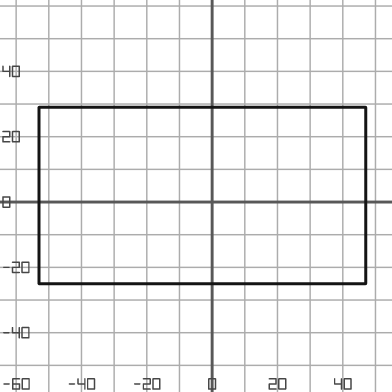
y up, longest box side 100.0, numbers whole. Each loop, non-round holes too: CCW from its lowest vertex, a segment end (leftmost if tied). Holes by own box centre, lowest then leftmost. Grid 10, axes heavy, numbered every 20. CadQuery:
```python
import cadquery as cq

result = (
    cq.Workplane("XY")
    .moveTo(-53.0, -25.0)
    .lineTo(47.0, -25.0)
    .lineTo(47.0, 29.0)
    .lineTo(-53.0, 29.0)
    .close()
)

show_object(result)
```